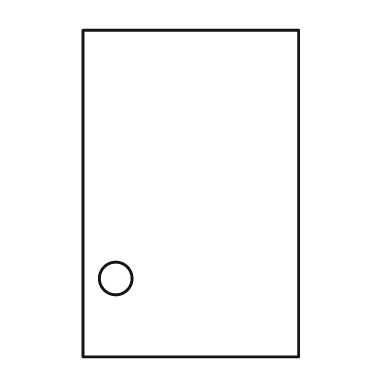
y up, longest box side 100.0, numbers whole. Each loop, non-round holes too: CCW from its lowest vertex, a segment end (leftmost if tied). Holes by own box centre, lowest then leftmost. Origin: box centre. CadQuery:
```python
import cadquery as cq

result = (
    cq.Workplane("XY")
    .moveTo(-33.0, -50.0)
    .lineTo(33.0, -50.0)
    .lineTo(33.0, 50.0)
    .lineTo(-33.0, 50.0)
    .close()
    .moveTo(-23.0, -26.0)
    .circle(5.0)
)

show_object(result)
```